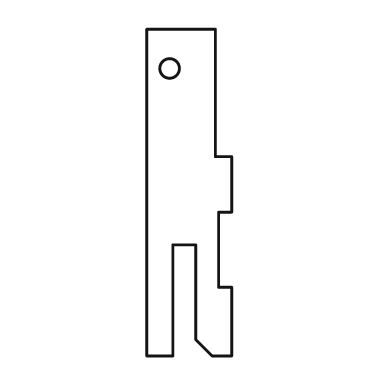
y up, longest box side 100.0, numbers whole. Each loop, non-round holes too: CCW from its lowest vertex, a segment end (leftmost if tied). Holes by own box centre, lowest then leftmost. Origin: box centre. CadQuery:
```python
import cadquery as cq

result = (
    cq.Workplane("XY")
    .moveTo(-13.0, -50.0)
    .lineTo(-5.0, -50.0)
    .lineTo(-5.0, -16.0)
    .lineTo(2.0, -16.0)
    .lineTo(2.0, -45.0)
    .lineTo(7.0, -50.0)
    .lineTo(13.0, -50.0)
    .lineTo(13.0, -29.0)
    .lineTo(9.0, -29.0)
    .lineTo(9.0, -6.0)
    .lineTo(13.0, -6.0)
    .lineTo(13.0, 11.0)
    .lineTo(8.0, 11.0)
    .lineTo(8.0, 50.0)
    .lineTo(-13.0, 50.0)
    .close()
    .moveTo(-6.0, 38.0)
    .circle(3.0)
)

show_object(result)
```